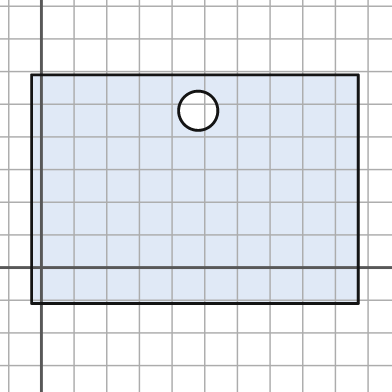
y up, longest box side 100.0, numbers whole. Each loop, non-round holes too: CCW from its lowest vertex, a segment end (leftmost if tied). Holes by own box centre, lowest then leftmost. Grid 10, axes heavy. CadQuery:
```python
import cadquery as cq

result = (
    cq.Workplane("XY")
    .moveTo(-3.0, -11.0)
    .lineTo(97.0, -11.0)
    .lineTo(97.0, 59.0)
    .lineTo(-3.0, 59.0)
    .close()
    .moveTo(48.0, 48.0)
    .circle(6.0)
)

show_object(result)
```